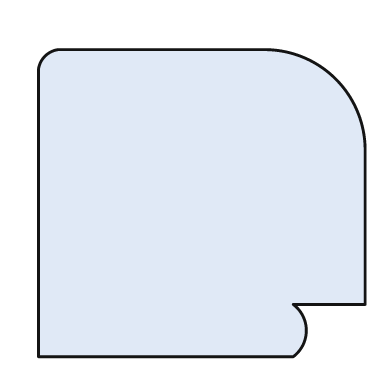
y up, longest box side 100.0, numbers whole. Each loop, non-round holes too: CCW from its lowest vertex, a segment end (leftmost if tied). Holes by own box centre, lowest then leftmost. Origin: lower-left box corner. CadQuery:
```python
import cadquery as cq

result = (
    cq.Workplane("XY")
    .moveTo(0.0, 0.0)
    .lineTo(78.0, 0.0)
    .threePointArc((82.0, 8.0), (78.0, 16.0))
    .lineTo(100.0, 16.0)
    .lineTo(100.0, 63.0)
    .threePointArc((91.0, 85.0), (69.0, 94.0))
    .lineTo(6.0, 94.0)
    .threePointArc((2.0, 92.0), (0.0, 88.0))
    .close()
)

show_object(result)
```